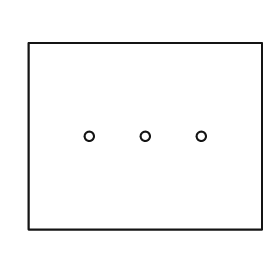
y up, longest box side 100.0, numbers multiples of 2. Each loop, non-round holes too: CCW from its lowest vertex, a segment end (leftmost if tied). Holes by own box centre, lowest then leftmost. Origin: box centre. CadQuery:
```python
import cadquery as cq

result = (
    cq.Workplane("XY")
    .moveTo(-50.0, -40.0)
    .lineTo(50.0, -40.0)
    .lineTo(50.0, 40.0)
    .lineTo(-50.0, 40.0)
    .close()
    .moveTo(-24.0, 0.0)
    .circle(2.0)
    .moveTo(0.0, 0.0)
    .circle(2.0)
    .moveTo(24.0, 0.0)
    .circle(2.0)
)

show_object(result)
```